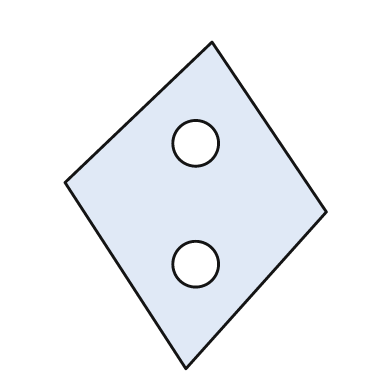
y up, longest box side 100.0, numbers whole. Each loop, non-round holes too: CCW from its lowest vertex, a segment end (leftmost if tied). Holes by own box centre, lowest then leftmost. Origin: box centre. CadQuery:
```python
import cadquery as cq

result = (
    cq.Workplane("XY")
    .moveTo(-3.0, -50.0)
    .lineTo(40.0, -2.0)
    .lineTo(5.0, 50.0)
    .lineTo(-40.0, 7.0)
    .close()
    .moveTo(0.0, -18.0)
    .circle(7.0)
    .moveTo(0.0, 19.0)
    .circle(7.0)
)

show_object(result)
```